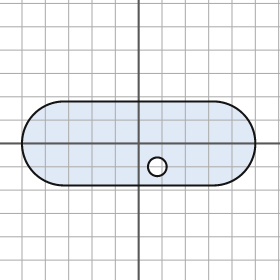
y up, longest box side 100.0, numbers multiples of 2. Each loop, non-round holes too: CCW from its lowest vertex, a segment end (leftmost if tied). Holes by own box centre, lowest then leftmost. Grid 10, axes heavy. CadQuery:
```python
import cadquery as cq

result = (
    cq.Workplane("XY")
    .moveTo(-32.0, -18.0)
    .lineTo(32.0, -18.0)
    .threePointArc((50.0, 0.0), (32.0, 18.0))
    .lineTo(-32.0, 18.0)
    .threePointArc((-50.0, 0.0), (-32.0, -18.0))
    .close()
    .moveTo(8.0, -10.0)
    .circle(4.0)
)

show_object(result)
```